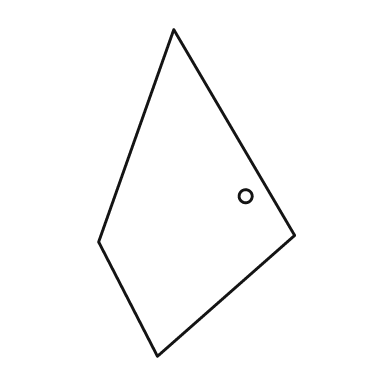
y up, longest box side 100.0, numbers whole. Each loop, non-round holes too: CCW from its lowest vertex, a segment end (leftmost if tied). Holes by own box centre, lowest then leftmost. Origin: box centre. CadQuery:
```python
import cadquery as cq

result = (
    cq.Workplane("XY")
    .moveTo(-12.0, -50.0)
    .lineTo(30.0, -13.0)
    .lineTo(-7.0, 50.0)
    .lineTo(-30.0, -15.0)
    .close()
    .moveTo(15.0, -1.0)
    .circle(2.0)
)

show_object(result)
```